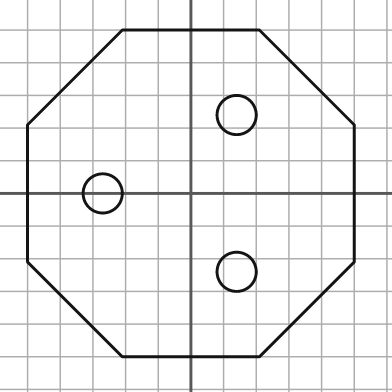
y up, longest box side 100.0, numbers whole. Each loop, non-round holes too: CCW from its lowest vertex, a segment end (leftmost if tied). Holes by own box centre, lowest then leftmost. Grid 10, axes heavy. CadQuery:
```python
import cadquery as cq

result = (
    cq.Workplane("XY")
    .moveTo(-21.0, -50.0)
    .lineTo(21.0, -50.0)
    .lineTo(50.0, -21.0)
    .lineTo(50.0, 21.0)
    .lineTo(21.0, 50.0)
    .lineTo(-21.0, 50.0)
    .lineTo(-50.0, 21.0)
    .lineTo(-50.0, -21.0)
    .close()
    .moveTo(14.0, -24.0)
    .circle(6.0)
    .moveTo(-27.0, 0.0)
    .circle(6.0)
    .moveTo(14.0, 24.0)
    .circle(6.0)
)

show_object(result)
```